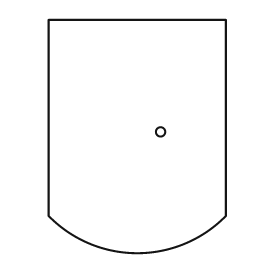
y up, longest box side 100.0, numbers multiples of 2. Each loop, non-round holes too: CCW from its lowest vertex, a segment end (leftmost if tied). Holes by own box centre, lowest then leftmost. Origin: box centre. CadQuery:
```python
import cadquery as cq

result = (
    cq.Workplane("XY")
    .moveTo(-38.0, -34.0)
    .threePointArc((0.0, -50.0), (38.0, -34.0))
    .lineTo(38.0, 50.0)
    .lineTo(-38.0, 50.0)
    .close()
    .moveTo(10.0, 2.0)
    .circle(2.0)
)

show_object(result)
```